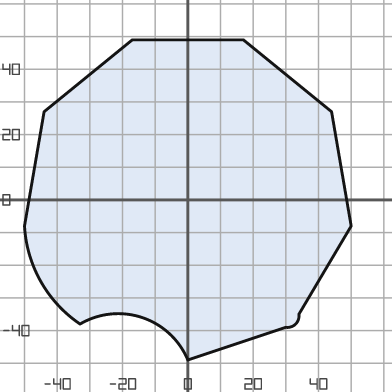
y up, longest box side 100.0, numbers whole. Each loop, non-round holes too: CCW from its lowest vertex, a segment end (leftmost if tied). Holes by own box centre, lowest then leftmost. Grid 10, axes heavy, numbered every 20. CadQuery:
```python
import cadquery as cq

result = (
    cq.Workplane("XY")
    .moveTo(0.0, -49.0)
    .lineTo(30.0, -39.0)
    .threePointArc((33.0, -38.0), (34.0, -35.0))
    .lineTo(50.0, -8.0)
    .lineTo(44.0, 27.0)
    .lineTo(17.0, 49.0)
    .lineTo(-17.0, 49.0)
    .lineTo(-44.0, 27.0)
    .lineTo(-50.0, -8.0)
    .threePointArc((-45.0, -25.0), (-33.0, -38.0))
    .threePointArc((-14.0, -36.0), (0.0, -49.0))
    .close()
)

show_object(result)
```